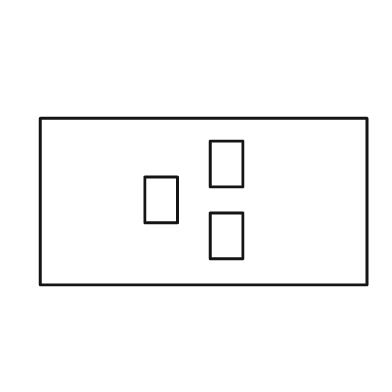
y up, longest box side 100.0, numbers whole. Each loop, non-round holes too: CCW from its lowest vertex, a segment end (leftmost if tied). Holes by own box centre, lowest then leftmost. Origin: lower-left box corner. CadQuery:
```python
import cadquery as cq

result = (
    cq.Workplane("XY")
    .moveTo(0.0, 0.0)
    .lineTo(100.0, 0.0)
    .lineTo(100.0, 51.0)
    .lineTo(0.0, 51.0)
    .close()
    .moveTo(52.0, 8.0)
    .lineTo(62.0, 8.0)
    .lineTo(62.0, 22.0)
    .lineTo(52.0, 22.0)
    .close()
    .moveTo(32.0, 19.0)
    .lineTo(42.0, 19.0)
    .lineTo(42.0, 33.0)
    .lineTo(32.0, 33.0)
    .close()
    .moveTo(52.0, 30.0)
    .lineTo(62.0, 30.0)
    .lineTo(62.0, 44.0)
    .lineTo(52.0, 44.0)
    .close()
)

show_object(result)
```